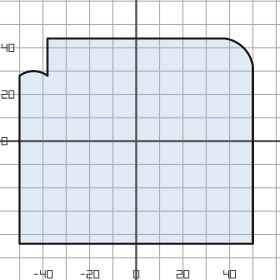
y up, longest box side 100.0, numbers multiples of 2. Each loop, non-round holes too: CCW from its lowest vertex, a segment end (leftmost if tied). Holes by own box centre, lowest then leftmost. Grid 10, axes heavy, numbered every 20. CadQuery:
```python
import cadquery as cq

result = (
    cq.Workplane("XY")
    .moveTo(-50.0, -44.0)
    .lineTo(50.0, -44.0)
    .lineTo(50.0, 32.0)
    .threePointArc((46.0, 40.0), (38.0, 44.0))
    .lineTo(-38.0, 44.0)
    .lineTo(-38.0, 28.0)
    .threePointArc((-44.0, 30.0), (-50.0, 28.0))
    .close()
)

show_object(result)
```